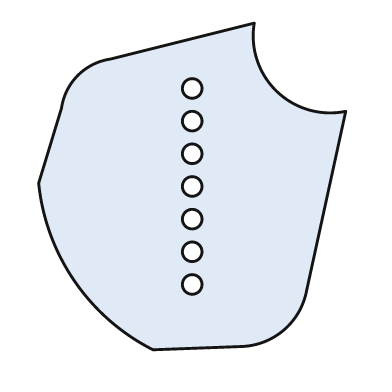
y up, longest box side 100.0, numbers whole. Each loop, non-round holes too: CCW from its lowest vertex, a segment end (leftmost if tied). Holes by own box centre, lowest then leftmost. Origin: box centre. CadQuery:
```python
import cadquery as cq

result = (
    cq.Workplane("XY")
    .moveTo(-12.0, -50.0)
    .lineTo(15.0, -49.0)
    .threePointArc((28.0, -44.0), (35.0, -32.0))
    .lineTo(47.0, 23.0)
    .threePointArc((26.0, 29.0), (19.0, 50.0))
    .lineTo(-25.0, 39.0)
    .threePointArc((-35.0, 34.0), (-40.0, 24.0))
    .lineTo(-47.0, 1.0)
    .threePointArc((-36.0, -29.0), (-12.0, -50.0))
    .close()
    .moveTo(0.0, -30.0)
    .circle(3.0)
    .moveTo(0.0, -20.0)
    .circle(3.0)
    .moveTo(0.0, -10.0)
    .circle(3.0)
    .moveTo(0.0, 0.0)
    .circle(3.0)
    .moveTo(0.0, 10.0)
    .circle(3.0)
    .moveTo(0.0, 20.0)
    .circle(3.0)
    .moveTo(0.0, 30.0)
    .circle(3.0)
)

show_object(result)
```